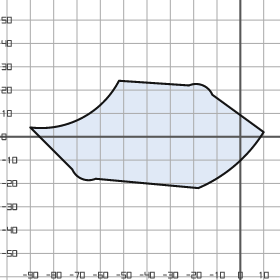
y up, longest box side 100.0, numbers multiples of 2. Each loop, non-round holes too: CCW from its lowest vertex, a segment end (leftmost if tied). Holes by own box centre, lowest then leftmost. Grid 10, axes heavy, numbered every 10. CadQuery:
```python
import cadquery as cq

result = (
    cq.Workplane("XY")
    .moveTo(-18.0, -22.0)
    .threePointArc((-2.0, -12.0), (10.0, 2.0))
    .lineTo(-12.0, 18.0)
    .threePointArc((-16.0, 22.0), (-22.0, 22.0))
    .lineTo(-52.0, 24.0)
    .threePointArc((-68.0, 8.0), (-90.0, 4.0))
    .lineTo(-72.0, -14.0)
    .threePointArc((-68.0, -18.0), (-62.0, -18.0))
    .close()
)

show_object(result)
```